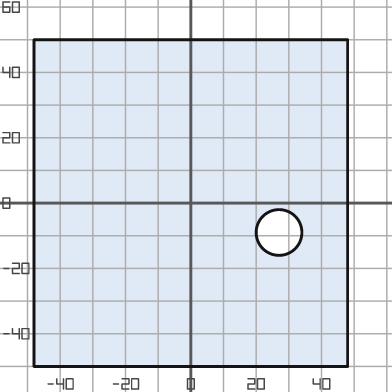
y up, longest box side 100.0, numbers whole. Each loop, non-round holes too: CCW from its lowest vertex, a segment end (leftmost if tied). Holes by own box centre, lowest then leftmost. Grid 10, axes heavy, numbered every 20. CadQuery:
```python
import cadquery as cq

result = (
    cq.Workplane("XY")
    .moveTo(-48.0, -50.0)
    .lineTo(48.0, -50.0)
    .lineTo(48.0, 50.0)
    .lineTo(-48.0, 50.0)
    .close()
    .moveTo(27.0, -9.0)
    .circle(7.0)
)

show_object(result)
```